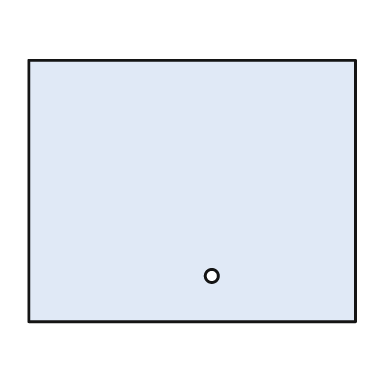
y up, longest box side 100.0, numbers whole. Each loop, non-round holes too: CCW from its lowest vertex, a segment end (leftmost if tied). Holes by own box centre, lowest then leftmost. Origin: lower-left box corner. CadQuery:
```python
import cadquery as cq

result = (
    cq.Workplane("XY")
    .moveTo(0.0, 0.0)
    .lineTo(100.0, 0.0)
    .lineTo(100.0, 80.0)
    .lineTo(0.0, 80.0)
    .close()
    .moveTo(56.0, 14.0)
    .circle(2.0)
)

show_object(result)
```